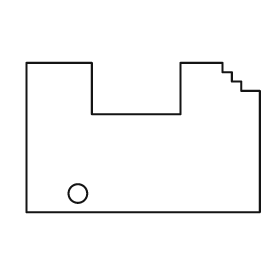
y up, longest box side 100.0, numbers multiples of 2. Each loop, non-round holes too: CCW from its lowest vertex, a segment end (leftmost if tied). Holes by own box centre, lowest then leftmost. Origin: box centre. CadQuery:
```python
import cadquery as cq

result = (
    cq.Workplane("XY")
    .moveTo(-50.0, -32.0)
    .lineTo(50.0, -32.0)
    .lineTo(50.0, 20.0)
    .lineTo(42.0, 20.0)
    .lineTo(42.0, 24.0)
    .lineTo(38.0, 24.0)
    .lineTo(38.0, 28.0)
    .lineTo(34.0, 28.0)
    .lineTo(34.0, 32.0)
    .lineTo(16.0, 32.0)
    .lineTo(16.0, 10.0)
    .lineTo(-22.0, 10.0)
    .lineTo(-22.0, 32.0)
    .lineTo(-50.0, 32.0)
    .close()
    .moveTo(-28.0, -24.0)
    .circle(4.0)
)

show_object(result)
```